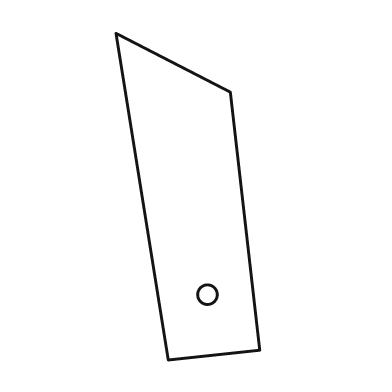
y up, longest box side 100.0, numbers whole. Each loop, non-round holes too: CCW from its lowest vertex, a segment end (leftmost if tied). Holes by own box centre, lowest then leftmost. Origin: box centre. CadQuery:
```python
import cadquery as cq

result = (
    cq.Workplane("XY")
    .moveTo(-6.0, -50.0)
    .lineTo(22.0, -47.0)
    .lineTo(13.0, 32.0)
    .lineTo(-22.0, 50.0)
    .close()
    .moveTo(6.0, -30.0)
    .circle(3.0)
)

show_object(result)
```